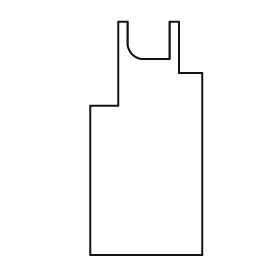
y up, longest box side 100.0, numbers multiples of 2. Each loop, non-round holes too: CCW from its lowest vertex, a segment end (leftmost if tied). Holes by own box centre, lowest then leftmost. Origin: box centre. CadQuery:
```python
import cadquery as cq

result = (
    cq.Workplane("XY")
    .moveTo(-24.0, -50.0)
    .lineTo(24.0, -50.0)
    .lineTo(24.0, 28.0)
    .lineTo(14.0, 28.0)
    .lineTo(14.0, 50.0)
    .lineTo(10.0, 50.0)
    .lineTo(10.0, 34.0)
    .lineTo(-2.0, 34.0)
    .threePointArc((-6.0, 36.0), (-8.0, 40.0))
    .lineTo(-8.0, 50.0)
    .lineTo(-12.0, 50.0)
    .lineTo(-12.0, 14.0)
    .lineTo(-24.0, 14.0)
    .close()
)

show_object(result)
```